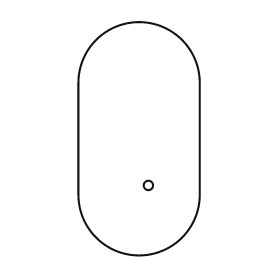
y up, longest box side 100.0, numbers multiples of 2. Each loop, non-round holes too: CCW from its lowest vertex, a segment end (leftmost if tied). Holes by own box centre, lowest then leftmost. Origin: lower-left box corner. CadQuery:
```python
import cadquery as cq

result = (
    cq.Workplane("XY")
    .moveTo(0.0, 26.0)
    .threePointArc((26.0, 0.0), (52.0, 26.0))
    .lineTo(52.0, 74.0)
    .threePointArc((26.0, 100.0), (0.0, 74.0))
    .close()
    .moveTo(30.0, 30.0)
    .circle(2.0)
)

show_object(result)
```